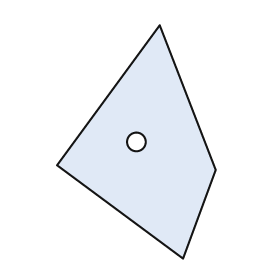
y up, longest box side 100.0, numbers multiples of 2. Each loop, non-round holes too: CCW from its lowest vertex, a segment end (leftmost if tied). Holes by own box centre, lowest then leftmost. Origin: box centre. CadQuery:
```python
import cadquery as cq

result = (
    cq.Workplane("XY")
    .moveTo(20.0, -50.0)
    .lineTo(34.0, -12.0)
    .lineTo(10.0, 50.0)
    .lineTo(-34.0, -10.0)
    .close()
    .moveTo(0.0, 0.0)
    .circle(4.0)
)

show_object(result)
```